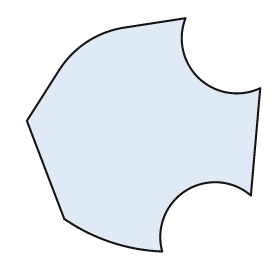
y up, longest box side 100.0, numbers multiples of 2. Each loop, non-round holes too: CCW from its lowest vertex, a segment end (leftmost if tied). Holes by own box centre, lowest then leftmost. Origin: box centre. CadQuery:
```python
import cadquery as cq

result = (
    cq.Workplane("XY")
    .moveTo(8.0, -50.0)
    .threePointArc((18.0, -24.0), (46.0, -26.0))
    .lineTo(50.0, 20.0)
    .threePointArc((24.0, 24.0), (18.0, 50.0))
    .lineTo(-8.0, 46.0)
    .threePointArc((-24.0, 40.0), (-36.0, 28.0))
    .lineTo(-50.0, 6.0)
    .lineTo(-34.0, -36.0)
    .threePointArc((-14.0, -46.0), (8.0, -50.0))
    .close()
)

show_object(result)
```